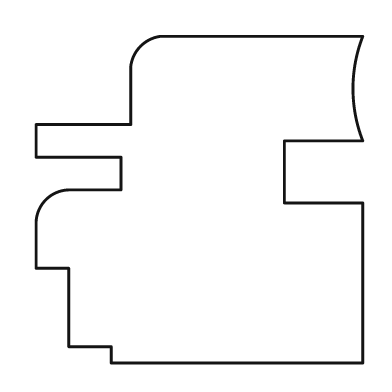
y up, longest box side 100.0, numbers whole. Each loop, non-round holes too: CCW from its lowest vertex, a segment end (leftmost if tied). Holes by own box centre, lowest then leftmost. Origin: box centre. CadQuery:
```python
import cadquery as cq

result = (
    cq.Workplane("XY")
    .moveTo(-27.0, -50.0)
    .lineTo(50.0, -50.0)
    .lineTo(50.0, -1.0)
    .lineTo(26.0, -1.0)
    .lineTo(26.0, 18.0)
    .lineTo(50.0, 18.0)
    .threePointArc((47.0, 34.0), (50.0, 50.0))
    .lineTo(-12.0, 50.0)
    .threePointArc((-18.0, 47.0), (-21.0, 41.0))
    .lineTo(-21.0, 23.0)
    .lineTo(-50.0, 23.0)
    .lineTo(-50.0, 13.0)
    .lineTo(-24.0, 13.0)
    .lineTo(-24.0, 3.0)
    .lineTo(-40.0, 3.0)
    .threePointArc((-47.0, 0.0), (-50.0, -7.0))
    .lineTo(-50.0, -21.0)
    .lineTo(-40.0, -21.0)
    .lineTo(-40.0, -45.0)
    .lineTo(-27.0, -45.0)
    .close()
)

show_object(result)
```